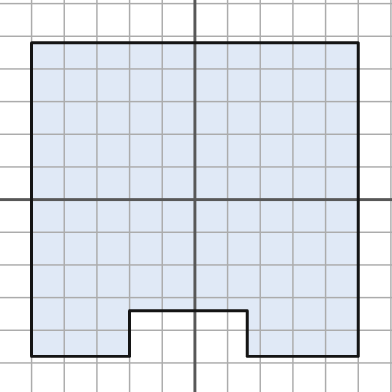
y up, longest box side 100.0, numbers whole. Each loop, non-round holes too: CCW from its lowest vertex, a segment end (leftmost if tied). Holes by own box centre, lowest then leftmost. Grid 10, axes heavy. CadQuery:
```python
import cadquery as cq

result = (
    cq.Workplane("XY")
    .moveTo(-50.0, -48.0)
    .lineTo(-20.0, -48.0)
    .lineTo(-20.0, -34.0)
    .lineTo(16.0, -34.0)
    .lineTo(16.0, -48.0)
    .lineTo(50.0, -48.0)
    .lineTo(50.0, 48.0)
    .lineTo(-50.0, 48.0)
    .close()
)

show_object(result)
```